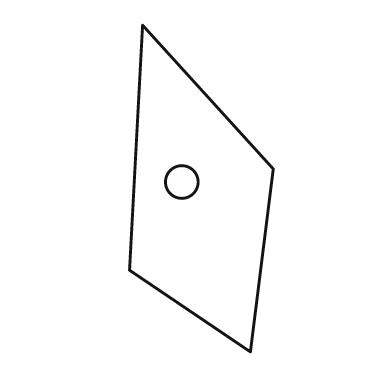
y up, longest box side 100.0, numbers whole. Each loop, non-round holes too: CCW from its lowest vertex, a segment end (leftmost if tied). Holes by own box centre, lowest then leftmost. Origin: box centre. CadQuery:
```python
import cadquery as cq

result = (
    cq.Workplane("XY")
    .moveTo(15.0, -50.0)
    .lineTo(22.0, 6.0)
    .lineTo(-18.0, 50.0)
    .lineTo(-22.0, -25.0)
    .close()
    .moveTo(-6.0, 2.0)
    .circle(5.0)
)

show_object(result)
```